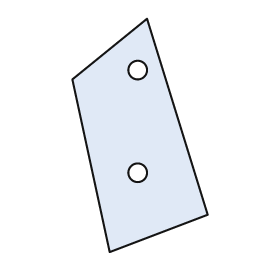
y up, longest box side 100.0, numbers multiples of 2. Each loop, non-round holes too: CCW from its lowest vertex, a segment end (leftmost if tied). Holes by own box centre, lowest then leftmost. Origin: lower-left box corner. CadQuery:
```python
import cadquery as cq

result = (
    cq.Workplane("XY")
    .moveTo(16.0, 0.0)
    .lineTo(58.0, 16.0)
    .lineTo(32.0, 100.0)
    .lineTo(0.0, 74.0)
    .close()
    .moveTo(28.0, 34.0)
    .circle(4.0)
    .moveTo(28.0, 78.0)
    .circle(4.0)
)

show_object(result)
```